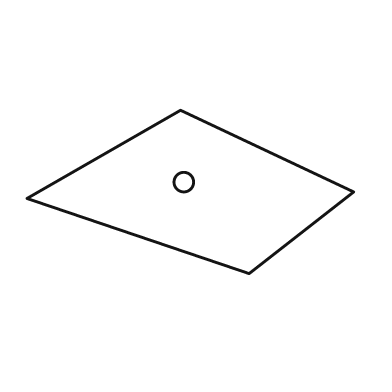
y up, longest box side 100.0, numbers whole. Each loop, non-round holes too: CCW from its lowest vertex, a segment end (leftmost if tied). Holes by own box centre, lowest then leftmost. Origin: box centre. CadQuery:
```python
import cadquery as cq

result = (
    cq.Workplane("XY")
    .moveTo(18.0, -25.0)
    .lineTo(50.0, 0.0)
    .lineTo(-3.0, 25.0)
    .lineTo(-50.0, -2.0)
    .close()
    .moveTo(-2.0, 3.0)
    .circle(3.0)
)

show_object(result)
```